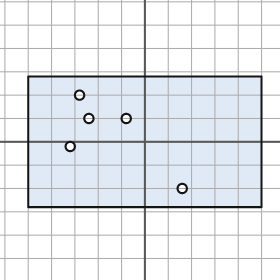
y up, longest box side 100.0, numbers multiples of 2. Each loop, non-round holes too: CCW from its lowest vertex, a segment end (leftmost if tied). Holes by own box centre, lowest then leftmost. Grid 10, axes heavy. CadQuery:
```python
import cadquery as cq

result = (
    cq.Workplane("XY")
    .moveTo(-50.0, -28.0)
    .lineTo(50.0, -28.0)
    .lineTo(50.0, 28.0)
    .lineTo(-50.0, 28.0)
    .close()
    .moveTo(16.0, -20.0)
    .circle(2.0)
    .moveTo(-32.0, -2.0)
    .circle(2.0)
    .moveTo(-24.0, 10.0)
    .circle(2.0)
    .moveTo(-8.0, 10.0)
    .circle(2.0)
    .moveTo(-28.0, 20.0)
    .circle(2.0)
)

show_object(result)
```